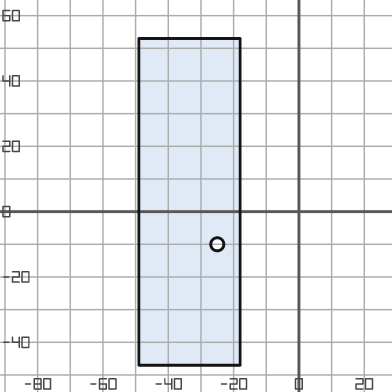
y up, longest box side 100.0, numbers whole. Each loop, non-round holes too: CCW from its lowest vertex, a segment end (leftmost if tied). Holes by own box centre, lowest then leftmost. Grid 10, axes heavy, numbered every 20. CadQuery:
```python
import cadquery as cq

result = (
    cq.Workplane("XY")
    .moveTo(-49.0, -47.0)
    .lineTo(-18.0, -47.0)
    .lineTo(-18.0, 53.0)
    .lineTo(-49.0, 53.0)
    .close()
    .moveTo(-25.0, -10.0)
    .circle(2.0)
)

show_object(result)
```